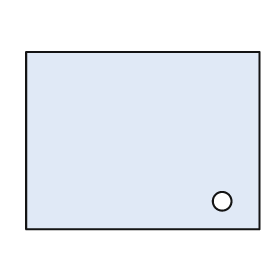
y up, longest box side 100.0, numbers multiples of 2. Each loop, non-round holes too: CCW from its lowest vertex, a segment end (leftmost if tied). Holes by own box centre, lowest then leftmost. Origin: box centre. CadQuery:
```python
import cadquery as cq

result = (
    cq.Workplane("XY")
    .moveTo(-50.0, -38.0)
    .lineTo(50.0, -38.0)
    .lineTo(50.0, 38.0)
    .lineTo(-50.0, 38.0)
    .close()
    .moveTo(34.0, -26.0)
    .circle(4.0)
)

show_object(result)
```